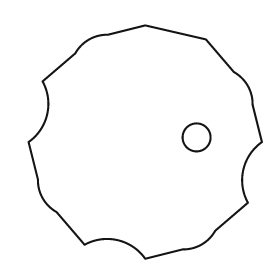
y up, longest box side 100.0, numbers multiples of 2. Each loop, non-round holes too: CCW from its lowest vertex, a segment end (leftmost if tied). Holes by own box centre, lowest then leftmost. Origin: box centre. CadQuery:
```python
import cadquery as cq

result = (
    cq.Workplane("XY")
    .moveTo(0.0, -50.0)
    .lineTo(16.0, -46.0)
    .threePointArc((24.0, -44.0), (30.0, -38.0))
    .lineTo(44.0, -26.0)
    .threePointArc((42.0, -12.0), (50.0, 0.0))
    .lineTo(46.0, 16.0)
    .threePointArc((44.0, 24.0), (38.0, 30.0))
    .lineTo(26.0, 44.0)
    .lineTo(0.0, 50.0)
    .lineTo(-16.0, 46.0)
    .threePointArc((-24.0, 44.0), (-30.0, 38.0))
    .lineTo(-44.0, 26.0)
    .threePointArc((-42.0, 12.0), (-50.0, 0.0))
    .lineTo(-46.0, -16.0)
    .threePointArc((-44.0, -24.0), (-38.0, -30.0))
    .lineTo(-26.0, -44.0)
    .threePointArc((-12.0, -42.0), (0.0, -50.0))
    .close()
    .moveTo(22.0, 2.0)
    .circle(6.0)
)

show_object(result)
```